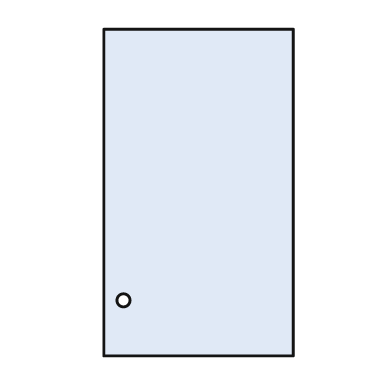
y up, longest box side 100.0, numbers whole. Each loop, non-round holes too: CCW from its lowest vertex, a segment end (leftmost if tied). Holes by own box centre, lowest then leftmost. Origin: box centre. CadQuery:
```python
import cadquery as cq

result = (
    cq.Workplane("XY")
    .moveTo(-29.0, -50.0)
    .lineTo(29.0, -50.0)
    .lineTo(29.0, 50.0)
    .lineTo(-29.0, 50.0)
    .close()
    .moveTo(-23.0, -33.0)
    .circle(2.0)
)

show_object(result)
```